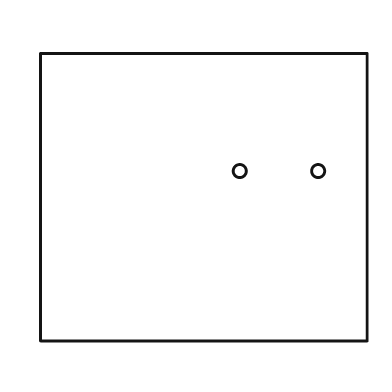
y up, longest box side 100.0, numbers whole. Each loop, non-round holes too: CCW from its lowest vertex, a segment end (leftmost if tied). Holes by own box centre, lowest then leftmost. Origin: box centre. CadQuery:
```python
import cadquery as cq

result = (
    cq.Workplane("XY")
    .moveTo(-50.0, -44.0)
    .lineTo(50.0, -44.0)
    .lineTo(50.0, 44.0)
    .lineTo(-50.0, 44.0)
    .close()
    .moveTo(11.0, 8.0)
    .circle(2.0)
    .moveTo(35.0, 8.0)
    .circle(2.0)
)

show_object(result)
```